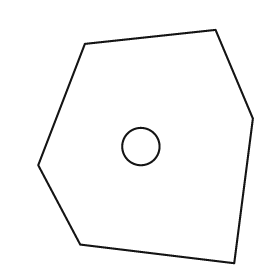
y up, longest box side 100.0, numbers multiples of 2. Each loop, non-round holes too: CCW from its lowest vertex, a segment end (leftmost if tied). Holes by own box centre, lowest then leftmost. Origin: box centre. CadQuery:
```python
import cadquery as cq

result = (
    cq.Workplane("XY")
    .moveTo(38.0, -50.0)
    .lineTo(46.0, 12.0)
    .lineTo(30.0, 50.0)
    .lineTo(-26.0, 44.0)
    .lineTo(-46.0, -8.0)
    .lineTo(-28.0, -42.0)
    .close()
    .moveTo(-2.0, 0.0)
    .circle(8.0)
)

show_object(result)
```